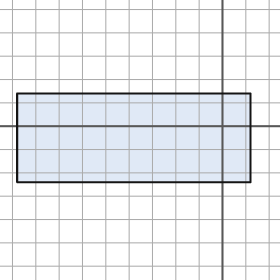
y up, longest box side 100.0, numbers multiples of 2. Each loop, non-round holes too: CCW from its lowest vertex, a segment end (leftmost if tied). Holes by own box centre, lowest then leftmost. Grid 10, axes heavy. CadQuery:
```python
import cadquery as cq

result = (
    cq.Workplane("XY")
    .moveTo(-88.0, -24.0)
    .lineTo(12.0, -24.0)
    .lineTo(12.0, 14.0)
    .lineTo(-88.0, 14.0)
    .close()
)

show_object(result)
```